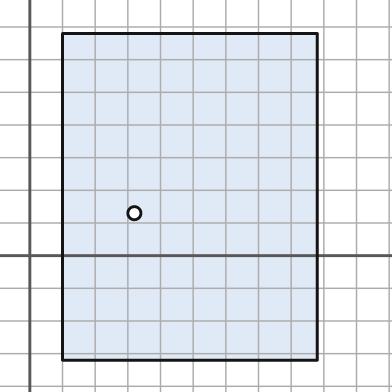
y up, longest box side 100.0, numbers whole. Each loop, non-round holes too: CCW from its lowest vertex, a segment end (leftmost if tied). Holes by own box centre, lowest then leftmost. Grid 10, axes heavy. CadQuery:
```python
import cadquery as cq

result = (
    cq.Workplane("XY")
    .moveTo(10.0, -32.0)
    .lineTo(88.0, -32.0)
    .lineTo(88.0, 68.0)
    .lineTo(10.0, 68.0)
    .close()
    .moveTo(32.0, 13.0)
    .circle(2.0)
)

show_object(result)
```